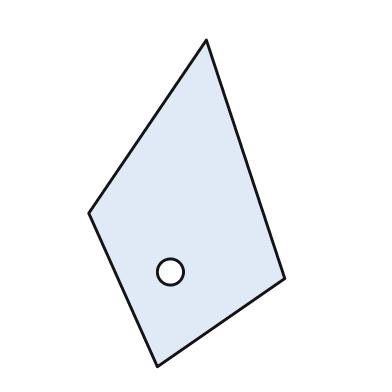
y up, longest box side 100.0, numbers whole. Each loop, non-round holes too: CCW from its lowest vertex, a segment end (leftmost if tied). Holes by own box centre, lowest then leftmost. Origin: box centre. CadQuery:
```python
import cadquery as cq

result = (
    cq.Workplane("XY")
    .moveTo(-9.0, -50.0)
    .lineTo(30.0, -23.0)
    .lineTo(6.0, 50.0)
    .lineTo(-30.0, -3.0)
    .close()
    .moveTo(-5.0, -21.0)
    .circle(4.0)
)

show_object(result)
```